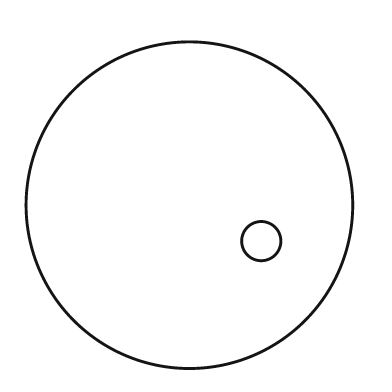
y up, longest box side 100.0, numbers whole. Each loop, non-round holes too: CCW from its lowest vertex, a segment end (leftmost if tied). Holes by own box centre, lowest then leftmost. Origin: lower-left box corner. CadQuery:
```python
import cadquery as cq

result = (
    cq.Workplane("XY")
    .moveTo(50.0, 50.0)
    .circle(50.0)
    .moveTo(72.0, 39.0)
    .circle(6.0)
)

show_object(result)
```